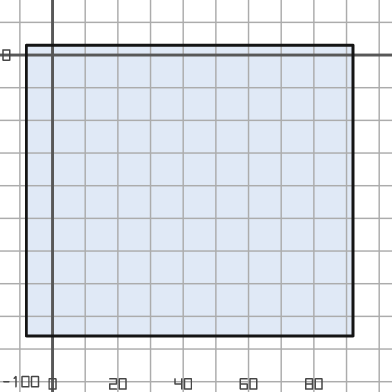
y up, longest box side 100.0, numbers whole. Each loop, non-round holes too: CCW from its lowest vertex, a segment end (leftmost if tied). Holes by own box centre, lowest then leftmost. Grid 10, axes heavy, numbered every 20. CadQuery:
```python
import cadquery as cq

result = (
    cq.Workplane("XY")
    .moveTo(-8.0, -86.0)
    .lineTo(92.0, -86.0)
    .lineTo(92.0, 3.0)
    .lineTo(-8.0, 3.0)
    .close()
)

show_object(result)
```